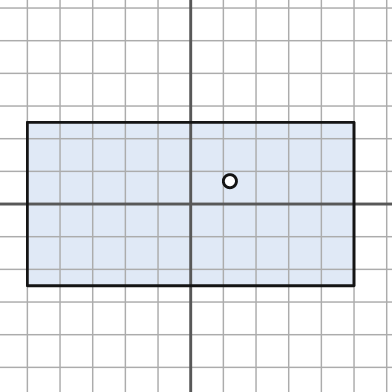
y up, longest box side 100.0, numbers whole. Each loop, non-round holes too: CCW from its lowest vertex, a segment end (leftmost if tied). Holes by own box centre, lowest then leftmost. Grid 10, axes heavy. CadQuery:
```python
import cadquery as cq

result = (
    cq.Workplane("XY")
    .moveTo(-50.0, -25.0)
    .lineTo(50.0, -25.0)
    .lineTo(50.0, 25.0)
    .lineTo(-50.0, 25.0)
    .close()
    .moveTo(12.0, 7.0)
    .circle(2.0)
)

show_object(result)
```